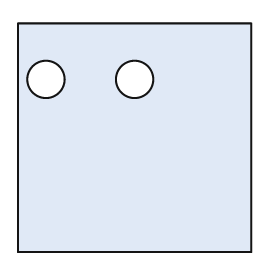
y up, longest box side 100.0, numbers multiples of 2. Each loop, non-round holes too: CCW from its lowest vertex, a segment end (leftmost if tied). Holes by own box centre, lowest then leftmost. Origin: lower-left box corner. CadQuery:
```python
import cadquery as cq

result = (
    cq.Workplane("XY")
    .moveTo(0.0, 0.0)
    .lineTo(100.0, 0.0)
    .lineTo(100.0, 98.0)
    .lineTo(0.0, 98.0)
    .close()
    .moveTo(12.0, 74.0)
    .circle(8.0)
    .moveTo(50.0, 74.0)
    .circle(8.0)
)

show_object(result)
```